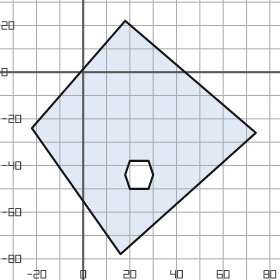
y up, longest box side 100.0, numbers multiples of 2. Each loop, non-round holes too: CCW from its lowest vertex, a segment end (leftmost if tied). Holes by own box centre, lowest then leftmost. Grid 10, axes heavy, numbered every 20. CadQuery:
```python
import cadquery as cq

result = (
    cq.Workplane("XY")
    .moveTo(16.0, -78.0)
    .lineTo(74.0, -26.0)
    .lineTo(18.0, 22.0)
    .lineTo(-22.0, -24.0)
    .close()
    .moveTo(20.0, -50.0)
    .lineTo(28.0, -50.0)
    .lineTo(30.0, -44.0)
    .lineTo(28.0, -38.0)
    .lineTo(20.0, -38.0)
    .lineTo(18.0, -44.0)
    .close()
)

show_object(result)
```